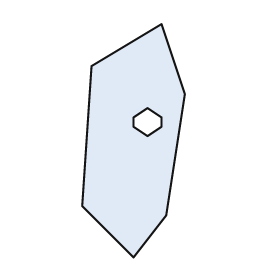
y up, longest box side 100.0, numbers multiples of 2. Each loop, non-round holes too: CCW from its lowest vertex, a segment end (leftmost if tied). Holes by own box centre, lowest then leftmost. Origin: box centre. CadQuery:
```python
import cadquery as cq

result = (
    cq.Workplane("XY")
    .moveTo(0.0, -50.0)
    .lineTo(14.0, -32.0)
    .lineTo(22.0, 20.0)
    .lineTo(12.0, 50.0)
    .lineTo(-18.0, 32.0)
    .lineTo(-22.0, -28.0)
    .close()
    .moveTo(6.0, 2.0)
    .lineTo(12.0, 6.0)
    .lineTo(12.0, 10.0)
    .lineTo(6.0, 14.0)
    .lineTo(0.0, 10.0)
    .lineTo(0.0, 6.0)
    .close()
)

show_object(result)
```